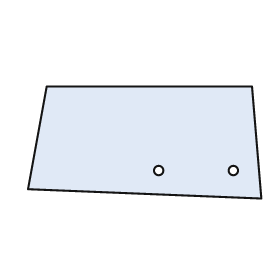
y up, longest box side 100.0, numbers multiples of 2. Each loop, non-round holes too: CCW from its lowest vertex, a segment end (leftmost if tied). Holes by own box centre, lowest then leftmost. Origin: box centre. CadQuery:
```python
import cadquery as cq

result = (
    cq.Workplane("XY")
    .moveTo(50.0, -24.0)
    .lineTo(46.0, 24.0)
    .lineTo(-42.0, 24.0)
    .lineTo(-50.0, -20.0)
    .close()
    .moveTo(6.0, -12.0)
    .circle(2.0)
    .moveTo(38.0, -12.0)
    .circle(2.0)
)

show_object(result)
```